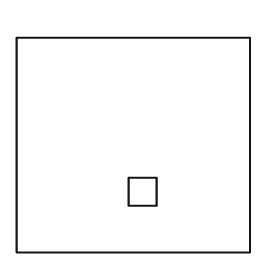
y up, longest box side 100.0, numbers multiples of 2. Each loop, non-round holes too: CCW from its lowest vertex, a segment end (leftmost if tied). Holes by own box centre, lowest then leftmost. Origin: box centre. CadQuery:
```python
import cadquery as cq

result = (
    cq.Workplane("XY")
    .moveTo(-50.0, -46.0)
    .lineTo(50.0, -46.0)
    .lineTo(50.0, 46.0)
    .lineTo(-50.0, 46.0)
    .close()
    .moveTo(-2.0, -26.0)
    .lineTo(10.0, -26.0)
    .lineTo(10.0, -14.0)
    .lineTo(-2.0, -14.0)
    .close()
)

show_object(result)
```